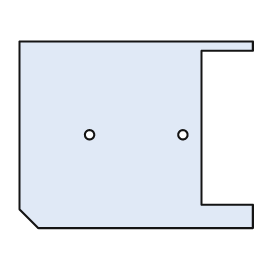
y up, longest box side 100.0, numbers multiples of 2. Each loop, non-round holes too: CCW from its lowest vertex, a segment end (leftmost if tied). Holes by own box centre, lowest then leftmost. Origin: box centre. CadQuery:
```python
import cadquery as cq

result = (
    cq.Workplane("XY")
    .moveTo(-42.0, -40.0)
    .lineTo(50.0, -40.0)
    .lineTo(50.0, -30.0)
    .lineTo(28.0, -30.0)
    .lineTo(28.0, 36.0)
    .lineTo(50.0, 36.0)
    .lineTo(50.0, 40.0)
    .lineTo(-50.0, 40.0)
    .lineTo(-50.0, -32.0)
    .close()
    .moveTo(-20.0, 0.0)
    .circle(2.0)
    .moveTo(20.0, 0.0)
    .circle(2.0)
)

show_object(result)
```